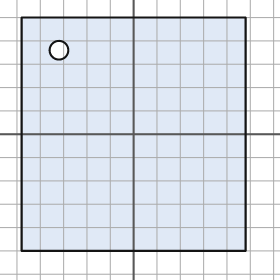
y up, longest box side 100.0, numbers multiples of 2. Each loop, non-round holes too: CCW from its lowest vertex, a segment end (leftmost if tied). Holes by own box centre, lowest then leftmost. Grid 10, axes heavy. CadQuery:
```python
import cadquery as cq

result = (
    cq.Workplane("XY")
    .moveTo(-48.0, -50.0)
    .lineTo(48.0, -50.0)
    .lineTo(48.0, 50.0)
    .lineTo(-48.0, 50.0)
    .close()
    .moveTo(-32.0, 36.0)
    .circle(4.0)
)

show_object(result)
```